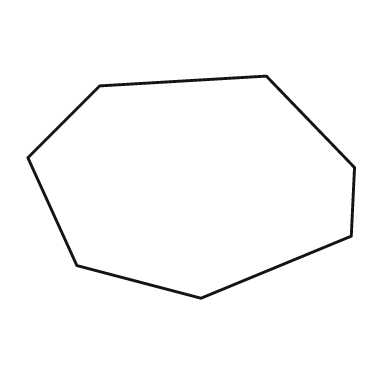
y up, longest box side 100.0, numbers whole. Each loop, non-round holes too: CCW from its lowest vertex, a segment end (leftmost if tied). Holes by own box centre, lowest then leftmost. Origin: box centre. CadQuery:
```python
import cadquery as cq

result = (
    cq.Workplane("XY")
    .moveTo(3.0, -34.0)
    .lineTo(49.0, -15.0)
    .lineTo(50.0, 6.0)
    .lineTo(23.0, 34.0)
    .lineTo(-28.0, 31.0)
    .lineTo(-50.0, 9.0)
    .lineTo(-35.0, -24.0)
    .close()
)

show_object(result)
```